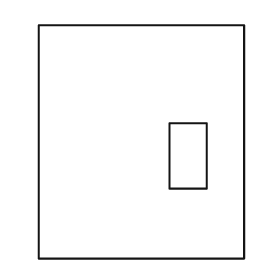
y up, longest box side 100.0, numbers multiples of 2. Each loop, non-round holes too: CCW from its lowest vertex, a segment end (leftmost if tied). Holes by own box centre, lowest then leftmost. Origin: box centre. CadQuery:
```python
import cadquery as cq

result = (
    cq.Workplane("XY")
    .moveTo(-44.0, -50.0)
    .lineTo(44.0, -50.0)
    .lineTo(44.0, 50.0)
    .lineTo(-44.0, 50.0)
    .close()
    .moveTo(12.0, -20.0)
    .lineTo(28.0, -20.0)
    .lineTo(28.0, 8.0)
    .lineTo(12.0, 8.0)
    .close()
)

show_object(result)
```